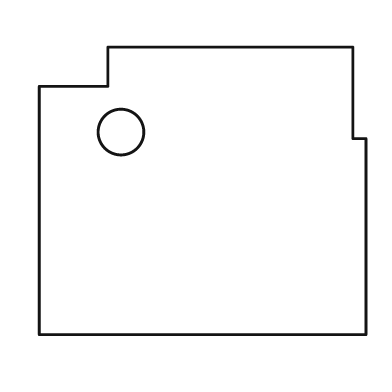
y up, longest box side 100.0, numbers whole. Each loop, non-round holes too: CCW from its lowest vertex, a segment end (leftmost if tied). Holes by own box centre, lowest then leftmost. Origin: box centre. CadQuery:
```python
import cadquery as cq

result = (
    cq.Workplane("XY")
    .moveTo(-50.0, -44.0)
    .lineTo(50.0, -44.0)
    .lineTo(50.0, 16.0)
    .lineTo(46.0, 16.0)
    .lineTo(46.0, 44.0)
    .lineTo(-29.0, 44.0)
    .lineTo(-29.0, 32.0)
    .lineTo(-50.0, 32.0)
    .close()
    .moveTo(-25.0, 18.0)
    .circle(7.0)
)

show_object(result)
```